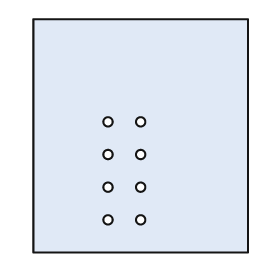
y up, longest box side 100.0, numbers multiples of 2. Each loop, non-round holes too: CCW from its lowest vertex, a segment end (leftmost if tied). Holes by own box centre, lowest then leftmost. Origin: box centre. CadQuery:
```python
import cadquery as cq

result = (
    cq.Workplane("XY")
    .moveTo(-46.0, -50.0)
    .lineTo(46.0, -50.0)
    .lineTo(46.0, 50.0)
    .lineTo(-46.0, 50.0)
    .close()
    .moveTo(-14.0, -36.0)
    .circle(2.0)
    .moveTo(0.0, -36.0)
    .circle(2.0)
    .moveTo(-14.0, -22.0)
    .circle(2.0)
    .moveTo(0.0, -22.0)
    .circle(2.0)
    .moveTo(-14.0, -8.0)
    .circle(2.0)
    .moveTo(0.0, -8.0)
    .circle(2.0)
    .moveTo(-14.0, 6.0)
    .circle(2.0)
    .moveTo(0.0, 6.0)
    .circle(2.0)
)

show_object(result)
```